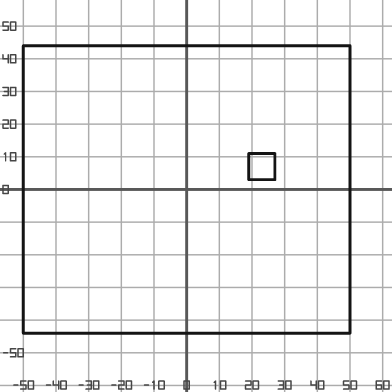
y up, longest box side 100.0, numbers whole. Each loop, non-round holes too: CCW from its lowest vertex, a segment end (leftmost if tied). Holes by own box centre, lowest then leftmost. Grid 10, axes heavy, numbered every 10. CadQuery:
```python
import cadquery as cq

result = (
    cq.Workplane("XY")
    .moveTo(-50.0, -44.0)
    .lineTo(50.0, -44.0)
    .lineTo(50.0, 44.0)
    .lineTo(-50.0, 44.0)
    .close()
    .moveTo(19.0, 3.0)
    .lineTo(27.0, 3.0)
    .lineTo(27.0, 11.0)
    .lineTo(19.0, 11.0)
    .close()
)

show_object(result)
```